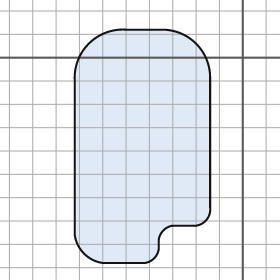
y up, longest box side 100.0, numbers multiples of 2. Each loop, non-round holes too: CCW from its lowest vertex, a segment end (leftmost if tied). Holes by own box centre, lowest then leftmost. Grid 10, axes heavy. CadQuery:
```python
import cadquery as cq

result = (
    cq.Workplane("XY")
    .moveTo(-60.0, -88.0)
    .lineTo(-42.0, -88.0)
    .threePointArc((-38.0, -86.0), (-36.0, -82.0))
    .lineTo(-36.0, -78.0)
    .threePointArc((-34.0, -74.0), (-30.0, -72.0))
    .lineTo(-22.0, -72.0)
    .threePointArc((-16.0, -70.0), (-14.0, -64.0))
    .lineTo(-14.0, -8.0)
    .threePointArc((-20.0, 6.0), (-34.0, 12.0))
    .lineTo(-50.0, 12.0)
    .threePointArc((-66.0, 6.0), (-72.0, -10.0))
    .lineTo(-72.0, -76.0)
    .threePointArc((-68.0, -84.0), (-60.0, -88.0))
    .close()
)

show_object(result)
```